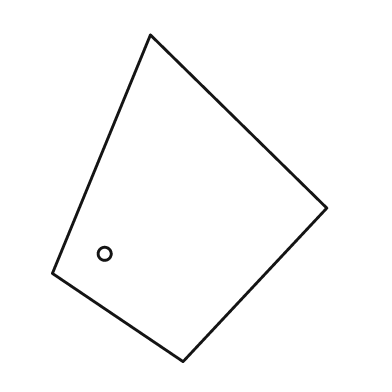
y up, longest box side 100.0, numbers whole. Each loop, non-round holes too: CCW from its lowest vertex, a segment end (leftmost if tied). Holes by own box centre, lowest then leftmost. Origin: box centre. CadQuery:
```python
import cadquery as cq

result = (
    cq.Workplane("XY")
    .moveTo(-2.0, -50.0)
    .lineTo(42.0, -3.0)
    .lineTo(-12.0, 50.0)
    .lineTo(-42.0, -23.0)
    .close()
    .moveTo(-26.0, -17.0)
    .circle(2.0)
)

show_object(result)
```